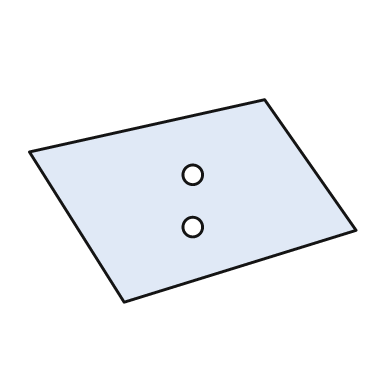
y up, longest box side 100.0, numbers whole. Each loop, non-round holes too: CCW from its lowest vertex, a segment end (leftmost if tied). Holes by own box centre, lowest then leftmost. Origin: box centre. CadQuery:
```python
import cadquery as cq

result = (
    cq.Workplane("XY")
    .moveTo(-21.0, -31.0)
    .lineTo(50.0, -9.0)
    .lineTo(22.0, 31.0)
    .lineTo(-50.0, 15.0)
    .close()
    .moveTo(0.0, -8.0)
    .circle(3.0)
    .moveTo(0.0, 8.0)
    .circle(3.0)
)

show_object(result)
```